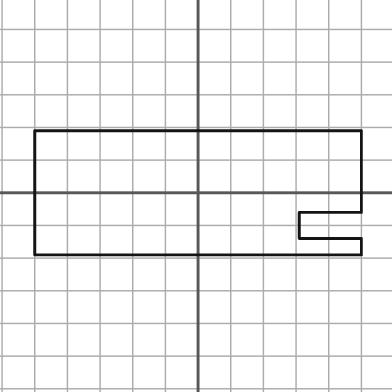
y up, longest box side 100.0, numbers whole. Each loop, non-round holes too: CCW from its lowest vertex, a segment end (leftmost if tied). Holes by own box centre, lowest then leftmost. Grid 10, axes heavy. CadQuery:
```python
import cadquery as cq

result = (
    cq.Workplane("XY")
    .moveTo(-50.0, -19.0)
    .lineTo(50.0, -19.0)
    .lineTo(50.0, -14.0)
    .lineTo(31.0, -14.0)
    .lineTo(31.0, -6.0)
    .lineTo(50.0, -6.0)
    .lineTo(50.0, 19.0)
    .lineTo(-50.0, 19.0)
    .close()
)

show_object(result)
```